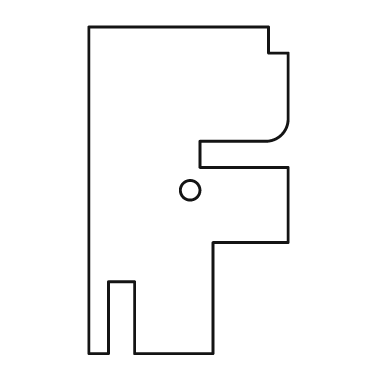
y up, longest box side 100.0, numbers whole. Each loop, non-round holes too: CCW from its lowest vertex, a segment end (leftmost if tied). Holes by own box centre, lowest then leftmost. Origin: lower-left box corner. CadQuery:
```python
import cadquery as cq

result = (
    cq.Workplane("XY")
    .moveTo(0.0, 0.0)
    .lineTo(6.0, 0.0)
    .lineTo(6.0, 22.0)
    .lineTo(14.0, 22.0)
    .lineTo(14.0, 0.0)
    .lineTo(38.0, 0.0)
    .lineTo(38.0, 34.0)
    .lineTo(61.0, 34.0)
    .lineTo(61.0, 57.0)
    .lineTo(34.0, 57.0)
    .lineTo(34.0, 65.0)
    .lineTo(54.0, 65.0)
    .threePointArc((59.0, 67.0), (61.0, 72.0))
    .lineTo(61.0, 92.0)
    .lineTo(55.0, 92.0)
    .lineTo(55.0, 100.0)
    .lineTo(0.0, 100.0)
    .close()
    .moveTo(31.0, 50.0)
    .circle(3.0)
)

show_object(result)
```